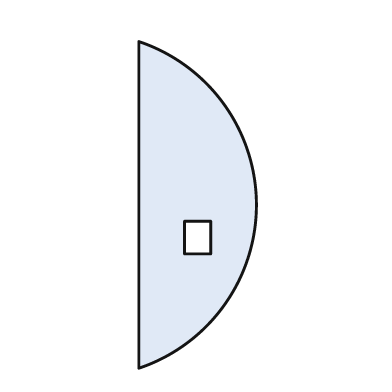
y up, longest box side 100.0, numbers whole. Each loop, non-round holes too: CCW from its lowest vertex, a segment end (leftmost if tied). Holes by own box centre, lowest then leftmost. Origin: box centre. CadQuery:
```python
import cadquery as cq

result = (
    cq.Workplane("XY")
    .moveTo(-18.0, -50.0)
    .threePointArc((18.0, 0.0), (-18.0, 50.0))
    .close()
    .moveTo(-4.0, -15.0)
    .lineTo(4.0, -15.0)
    .lineTo(4.0, -5.0)
    .lineTo(-4.0, -5.0)
    .close()
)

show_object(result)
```